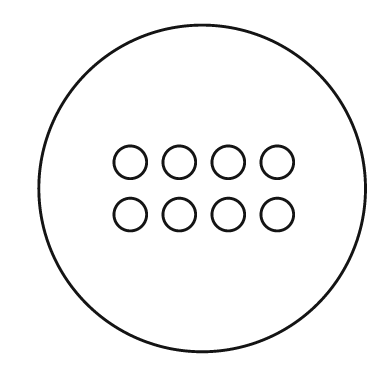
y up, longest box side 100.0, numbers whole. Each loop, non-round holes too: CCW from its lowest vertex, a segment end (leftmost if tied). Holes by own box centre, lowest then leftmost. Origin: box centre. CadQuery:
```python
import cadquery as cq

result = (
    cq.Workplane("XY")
    .moveTo(0.0, 0.0)
    .circle(50.0)
    .moveTo(-22.0, -8.0)
    .circle(5.0)
    .moveTo(-7.0, -8.0)
    .circle(5.0)
    .moveTo(8.0, -8.0)
    .circle(5.0)
    .moveTo(23.0, -8.0)
    .circle(5.0)
    .moveTo(-22.0, 8.0)
    .circle(5.0)
    .moveTo(-7.0, 8.0)
    .circle(5.0)
    .moveTo(8.0, 8.0)
    .circle(5.0)
    .moveTo(23.0, 8.0)
    .circle(5.0)
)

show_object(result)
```